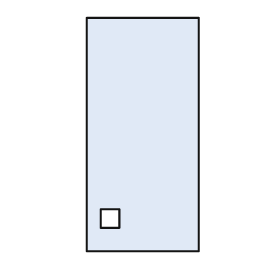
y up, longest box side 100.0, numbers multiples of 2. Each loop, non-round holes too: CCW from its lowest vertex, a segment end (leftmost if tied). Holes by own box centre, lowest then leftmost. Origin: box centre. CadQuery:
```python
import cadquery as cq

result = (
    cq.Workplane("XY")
    .moveTo(-24.0, -50.0)
    .lineTo(24.0, -50.0)
    .lineTo(24.0, 50.0)
    .lineTo(-24.0, 50.0)
    .close()
    .moveTo(-18.0, -40.0)
    .lineTo(-10.0, -40.0)
    .lineTo(-10.0, -32.0)
    .lineTo(-18.0, -32.0)
    .close()
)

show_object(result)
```